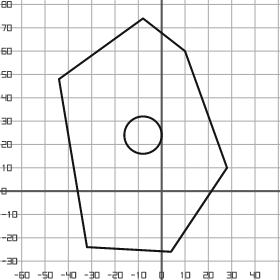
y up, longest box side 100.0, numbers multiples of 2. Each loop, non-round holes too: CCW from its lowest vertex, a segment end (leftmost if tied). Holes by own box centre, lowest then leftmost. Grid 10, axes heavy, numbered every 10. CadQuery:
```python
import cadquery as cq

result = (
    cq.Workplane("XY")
    .moveTo(4.0, -26.0)
    .lineTo(28.0, 10.0)
    .lineTo(10.0, 60.0)
    .lineTo(-8.0, 74.0)
    .lineTo(-44.0, 48.0)
    .lineTo(-32.0, -24.0)
    .close()
    .moveTo(-8.0, 24.0)
    .circle(8.0)
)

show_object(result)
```